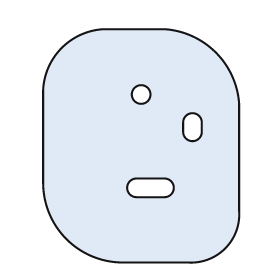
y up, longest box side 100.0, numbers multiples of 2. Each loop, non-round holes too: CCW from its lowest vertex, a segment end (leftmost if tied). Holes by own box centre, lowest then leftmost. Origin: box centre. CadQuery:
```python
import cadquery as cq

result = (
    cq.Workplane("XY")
    .moveTo(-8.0, -50.0)
    .lineTo(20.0, -50.0)
    .threePointArc((36.0, -44.0), (42.0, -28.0))
    .lineTo(42.0, 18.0)
    .threePointArc((32.0, 40.0), (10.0, 50.0))
    .lineTo(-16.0, 50.0)
    .threePointArc((-34.0, 42.0), (-42.0, 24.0))
    .lineTo(-42.0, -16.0)
    .threePointArc((-32.0, -40.0), (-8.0, -50.0))
    .close()
    .moveTo(-2.0, -22.0)
    .lineTo(10.0, -22.0)
    .threePointArc((14.0, -18.0), (10.0, -14.0))
    .lineTo(-2.0, -14.0)
    .threePointArc((-6.0, -18.0), (-2.0, -22.0))
    .close()
    .moveTo(18.0, 6.0)
    .threePointArc((22.0, 2.0), (26.0, 6.0))
    .lineTo(26.0, 10.0)
    .threePointArc((22.0, 14.0), (18.0, 10.0))
    .close()
    .moveTo(0.0, 22.0)
    .circle(4.0)
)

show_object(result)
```